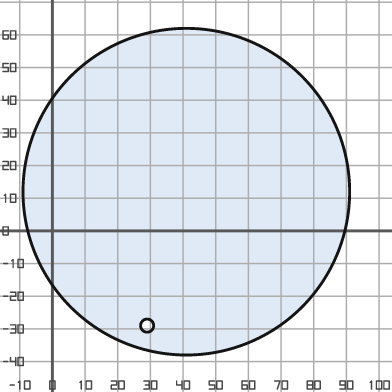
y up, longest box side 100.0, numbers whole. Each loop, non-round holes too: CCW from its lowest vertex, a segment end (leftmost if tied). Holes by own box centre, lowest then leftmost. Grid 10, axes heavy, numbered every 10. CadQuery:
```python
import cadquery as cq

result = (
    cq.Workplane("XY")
    .moveTo(41.0, 12.0)
    .circle(50.0)
    .moveTo(29.0, -29.0)
    .circle(2.0)
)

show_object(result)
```